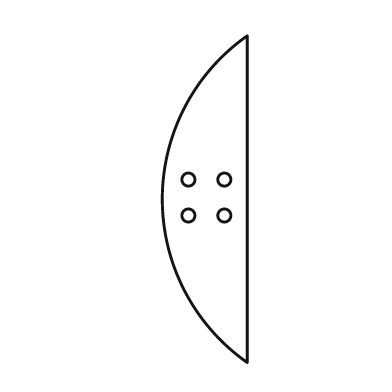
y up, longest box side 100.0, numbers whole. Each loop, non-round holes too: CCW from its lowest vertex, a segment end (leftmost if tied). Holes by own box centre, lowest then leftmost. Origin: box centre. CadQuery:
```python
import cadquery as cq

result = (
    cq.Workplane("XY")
    .moveTo(13.0, -50.0)
    .lineTo(13.0, 50.0)
    .threePointArc((-13.0, 0.0), (13.0, -50.0))
    .close()
    .moveTo(-5.0, -5.0)
    .circle(2.0)
    .moveTo(6.0, -5.0)
    .circle(2.0)
    .moveTo(-5.0, 6.0)
    .circle(2.0)
    .moveTo(6.0, 6.0)
    .circle(2.0)
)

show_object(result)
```